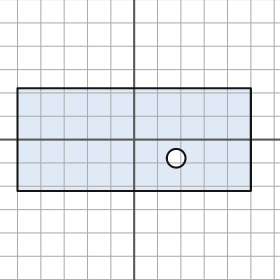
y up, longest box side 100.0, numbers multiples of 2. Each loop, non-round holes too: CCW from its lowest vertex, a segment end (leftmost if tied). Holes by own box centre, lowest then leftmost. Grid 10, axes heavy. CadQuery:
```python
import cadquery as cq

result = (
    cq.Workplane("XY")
    .moveTo(-50.0, -22.0)
    .lineTo(50.0, -22.0)
    .lineTo(50.0, 22.0)
    .lineTo(-50.0, 22.0)
    .close()
    .moveTo(18.0, -8.0)
    .circle(4.0)
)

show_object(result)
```